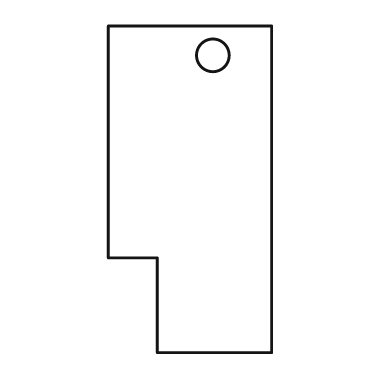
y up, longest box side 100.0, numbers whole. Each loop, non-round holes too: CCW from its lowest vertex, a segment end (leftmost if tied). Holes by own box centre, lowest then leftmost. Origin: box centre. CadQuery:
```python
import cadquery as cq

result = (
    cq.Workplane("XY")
    .moveTo(-10.0, -50.0)
    .lineTo(25.0, -50.0)
    .lineTo(25.0, 50.0)
    .lineTo(-25.0, 50.0)
    .lineTo(-25.0, -21.0)
    .lineTo(-10.0, -21.0)
    .close()
    .moveTo(7.0, 41.0)
    .circle(5.0)
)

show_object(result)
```